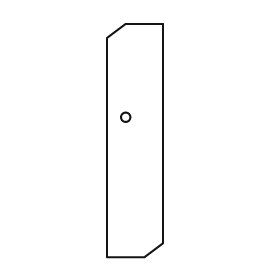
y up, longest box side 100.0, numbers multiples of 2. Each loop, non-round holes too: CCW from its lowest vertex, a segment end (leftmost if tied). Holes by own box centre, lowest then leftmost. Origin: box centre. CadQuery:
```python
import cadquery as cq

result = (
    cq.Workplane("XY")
    .moveTo(-12.0, -50.0)
    .lineTo(4.0, -50.0)
    .lineTo(12.0, -44.0)
    .lineTo(12.0, 50.0)
    .lineTo(-4.0, 50.0)
    .lineTo(-12.0, 44.0)
    .close()
    .moveTo(-4.0, 10.0)
    .circle(2.0)
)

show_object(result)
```